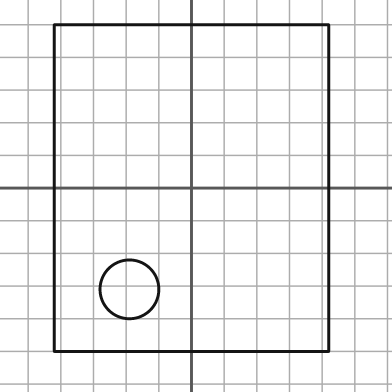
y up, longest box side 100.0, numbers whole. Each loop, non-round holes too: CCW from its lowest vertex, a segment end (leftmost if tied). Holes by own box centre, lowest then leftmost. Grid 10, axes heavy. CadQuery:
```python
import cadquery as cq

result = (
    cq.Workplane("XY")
    .moveTo(-42.0, -50.0)
    .lineTo(42.0, -50.0)
    .lineTo(42.0, 50.0)
    .lineTo(-42.0, 50.0)
    .close()
    .moveTo(-19.0, -31.0)
    .circle(9.0)
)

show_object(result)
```